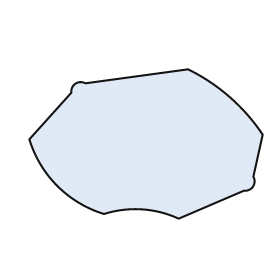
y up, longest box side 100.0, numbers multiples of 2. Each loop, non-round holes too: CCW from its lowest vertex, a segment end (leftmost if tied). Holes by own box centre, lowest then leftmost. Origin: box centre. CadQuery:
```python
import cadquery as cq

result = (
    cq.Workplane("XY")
    .moveTo(14.0, -32.0)
    .lineTo(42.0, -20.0)
    .threePointArc((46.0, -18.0), (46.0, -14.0))
    .lineTo(50.0, 4.0)
    .threePointArc((36.0, 20.0), (18.0, 32.0))
    .lineTo(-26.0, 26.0)
    .threePointArc((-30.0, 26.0), (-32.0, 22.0))
    .lineTo(-50.0, 2.0)
    .threePointArc((-38.0, -18.0), (-18.0, -30.0))
    .threePointArc((-2.0, -28.0), (14.0, -32.0))
    .close()
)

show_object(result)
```